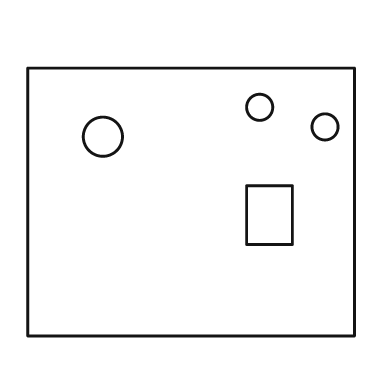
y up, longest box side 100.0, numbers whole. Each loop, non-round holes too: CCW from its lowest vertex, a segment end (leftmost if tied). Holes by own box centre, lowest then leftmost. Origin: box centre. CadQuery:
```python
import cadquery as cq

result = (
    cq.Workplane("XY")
    .moveTo(-50.0, -41.0)
    .lineTo(50.0, -41.0)
    .lineTo(50.0, 41.0)
    .lineTo(-50.0, 41.0)
    .close()
    .moveTo(17.0, -13.0)
    .lineTo(31.0, -13.0)
    .lineTo(31.0, 5.0)
    .lineTo(17.0, 5.0)
    .close()
    .moveTo(-27.0, 20.0)
    .circle(6.0)
    .moveTo(41.0, 23.0)
    .circle(4.0)
    .moveTo(21.0, 29.0)
    .circle(4.0)
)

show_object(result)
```